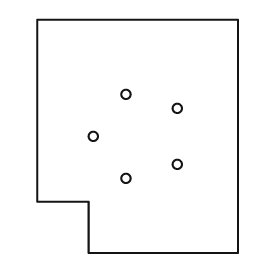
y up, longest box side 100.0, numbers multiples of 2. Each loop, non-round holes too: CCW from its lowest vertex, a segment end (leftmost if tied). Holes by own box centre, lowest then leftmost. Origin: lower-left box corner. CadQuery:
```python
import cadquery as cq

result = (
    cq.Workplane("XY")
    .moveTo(22.0, 0.0)
    .lineTo(86.0, 0.0)
    .lineTo(86.0, 100.0)
    .lineTo(0.0, 100.0)
    .lineTo(0.0, 22.0)
    .lineTo(22.0, 22.0)
    .close()
    .moveTo(38.0, 32.0)
    .circle(2.0)
    .moveTo(60.0, 38.0)
    .circle(2.0)
    .moveTo(24.0, 50.0)
    .circle(2.0)
    .moveTo(60.0, 62.0)
    .circle(2.0)
    .moveTo(38.0, 68.0)
    .circle(2.0)
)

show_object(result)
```